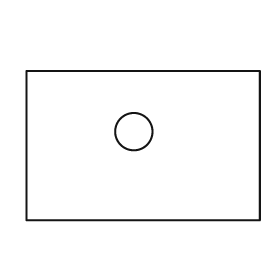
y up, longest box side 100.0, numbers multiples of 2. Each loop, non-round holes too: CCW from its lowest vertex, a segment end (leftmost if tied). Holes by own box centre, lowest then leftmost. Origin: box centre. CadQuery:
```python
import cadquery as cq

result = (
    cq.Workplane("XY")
    .moveTo(-50.0, -32.0)
    .lineTo(50.0, -32.0)
    .lineTo(50.0, 32.0)
    .lineTo(-50.0, 32.0)
    .close()
    .moveTo(-4.0, 6.0)
    .circle(8.0)
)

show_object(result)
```